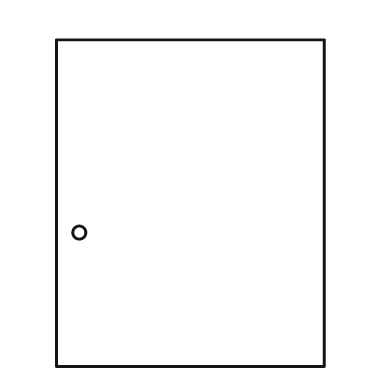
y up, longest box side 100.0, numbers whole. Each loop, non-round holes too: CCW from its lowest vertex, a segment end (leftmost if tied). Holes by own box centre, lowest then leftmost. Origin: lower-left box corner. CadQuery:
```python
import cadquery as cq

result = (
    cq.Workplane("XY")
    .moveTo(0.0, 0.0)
    .lineTo(82.0, 0.0)
    .lineTo(82.0, 100.0)
    .lineTo(0.0, 100.0)
    .close()
    .moveTo(7.0, 41.0)
    .circle(2.0)
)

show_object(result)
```